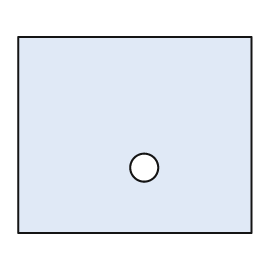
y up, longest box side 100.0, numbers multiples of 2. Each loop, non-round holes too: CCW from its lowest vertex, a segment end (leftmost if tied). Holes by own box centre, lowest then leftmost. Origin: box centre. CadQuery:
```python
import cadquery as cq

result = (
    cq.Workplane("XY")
    .moveTo(-50.0, -42.0)
    .lineTo(50.0, -42.0)
    .lineTo(50.0, 42.0)
    .lineTo(-50.0, 42.0)
    .close()
    .moveTo(4.0, -14.0)
    .circle(6.0)
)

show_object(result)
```